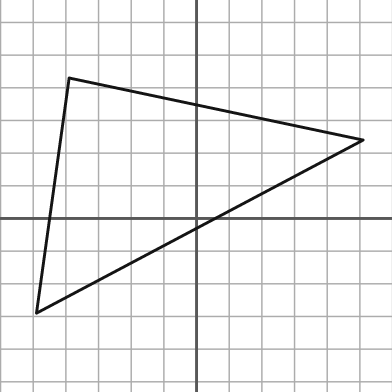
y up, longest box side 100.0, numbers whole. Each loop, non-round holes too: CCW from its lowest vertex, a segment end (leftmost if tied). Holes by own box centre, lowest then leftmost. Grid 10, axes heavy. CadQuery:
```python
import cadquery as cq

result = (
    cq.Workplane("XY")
    .moveTo(-49.0, -29.0)
    .lineTo(51.0, 24.0)
    .lineTo(-39.0, 43.0)
    .close()
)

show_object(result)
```